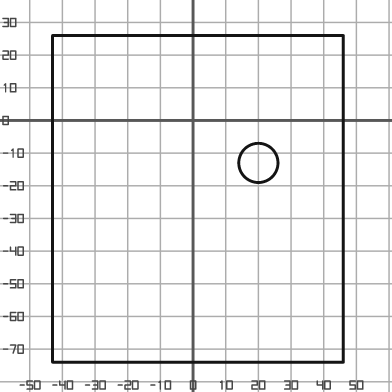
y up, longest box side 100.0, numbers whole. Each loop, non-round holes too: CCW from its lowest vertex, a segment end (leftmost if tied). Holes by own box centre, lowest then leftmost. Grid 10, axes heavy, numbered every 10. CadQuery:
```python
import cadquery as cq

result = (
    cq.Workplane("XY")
    .moveTo(-43.0, -74.0)
    .lineTo(46.0, -74.0)
    .lineTo(46.0, 26.0)
    .lineTo(-43.0, 26.0)
    .close()
    .moveTo(20.0, -13.0)
    .circle(6.0)
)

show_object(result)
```